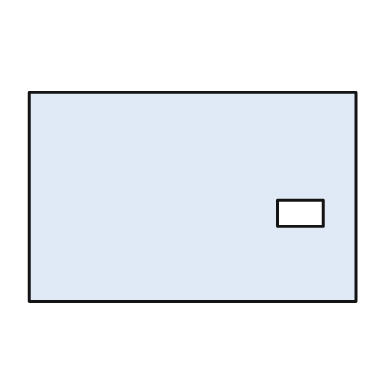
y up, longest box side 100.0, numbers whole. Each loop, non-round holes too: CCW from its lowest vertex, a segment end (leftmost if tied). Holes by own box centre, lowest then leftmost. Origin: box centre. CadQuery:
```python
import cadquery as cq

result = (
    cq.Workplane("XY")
    .moveTo(-50.0, -32.0)
    .lineTo(50.0, -32.0)
    .lineTo(50.0, 32.0)
    .lineTo(-50.0, 32.0)
    .close()
    .moveTo(26.0, -9.0)
    .lineTo(40.0, -9.0)
    .lineTo(40.0, -1.0)
    .lineTo(26.0, -1.0)
    .close()
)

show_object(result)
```